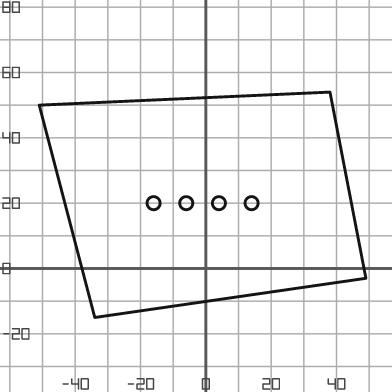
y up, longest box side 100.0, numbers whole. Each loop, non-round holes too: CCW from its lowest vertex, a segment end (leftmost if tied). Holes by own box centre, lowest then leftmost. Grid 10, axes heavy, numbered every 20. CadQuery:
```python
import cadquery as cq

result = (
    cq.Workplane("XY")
    .moveTo(-34.0, -15.0)
    .lineTo(49.0, -3.0)
    .lineTo(38.0, 54.0)
    .lineTo(-51.0, 50.0)
    .close()
    .moveTo(-16.0, 20.0)
    .circle(2.0)
    .moveTo(-6.0, 20.0)
    .circle(2.0)
    .moveTo(4.0, 20.0)
    .circle(2.0)
    .moveTo(14.0, 20.0)
    .circle(2.0)
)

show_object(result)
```